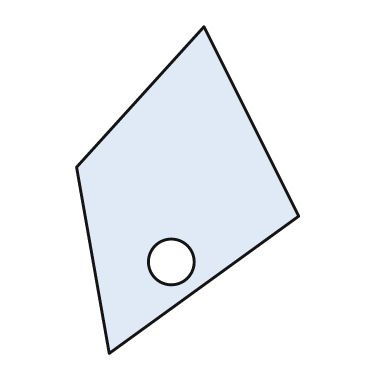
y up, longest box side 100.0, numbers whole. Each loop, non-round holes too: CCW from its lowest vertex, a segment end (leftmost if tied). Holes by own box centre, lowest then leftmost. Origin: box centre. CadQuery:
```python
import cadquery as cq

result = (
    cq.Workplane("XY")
    .moveTo(-24.0, -50.0)
    .lineTo(34.0, -8.0)
    .lineTo(5.0, 50.0)
    .lineTo(-34.0, 7.0)
    .close()
    .moveTo(-5.0, -22.0)
    .circle(7.0)
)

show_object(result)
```